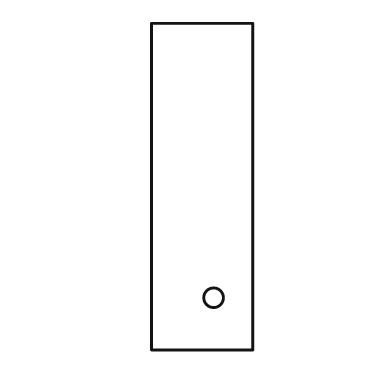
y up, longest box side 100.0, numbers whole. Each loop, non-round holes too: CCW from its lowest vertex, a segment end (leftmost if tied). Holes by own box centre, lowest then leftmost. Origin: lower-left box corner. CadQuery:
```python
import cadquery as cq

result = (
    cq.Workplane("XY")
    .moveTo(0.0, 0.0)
    .lineTo(31.0, 0.0)
    .lineTo(31.0, 100.0)
    .lineTo(0.0, 100.0)
    .close()
    .moveTo(19.0, 16.0)
    .circle(3.0)
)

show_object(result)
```